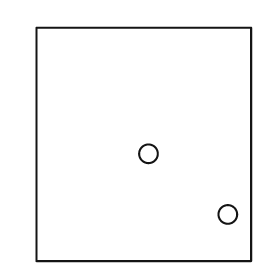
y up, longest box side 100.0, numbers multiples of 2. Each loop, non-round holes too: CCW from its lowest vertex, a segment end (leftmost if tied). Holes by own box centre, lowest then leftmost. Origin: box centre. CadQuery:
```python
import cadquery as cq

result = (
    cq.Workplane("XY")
    .moveTo(-46.0, -50.0)
    .lineTo(46.0, -50.0)
    .lineTo(46.0, 50.0)
    .lineTo(-46.0, 50.0)
    .close()
    .moveTo(36.0, -30.0)
    .circle(4.0)
    .moveTo(2.0, -4.0)
    .circle(4.0)
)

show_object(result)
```